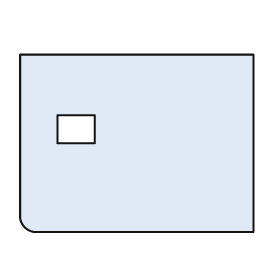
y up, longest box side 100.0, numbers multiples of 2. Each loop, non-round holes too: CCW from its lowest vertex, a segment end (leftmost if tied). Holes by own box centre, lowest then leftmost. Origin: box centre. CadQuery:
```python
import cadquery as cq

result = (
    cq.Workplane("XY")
    .moveTo(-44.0, -38.0)
    .lineTo(50.0, -38.0)
    .lineTo(50.0, 38.0)
    .lineTo(-50.0, 38.0)
    .lineTo(-50.0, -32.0)
    .threePointArc((-48.0, -36.0), (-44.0, -38.0))
    .close()
    .moveTo(-34.0, 0.0)
    .lineTo(-18.0, 0.0)
    .lineTo(-18.0, 12.0)
    .lineTo(-34.0, 12.0)
    .close()
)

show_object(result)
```